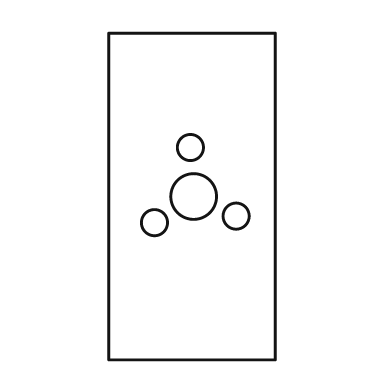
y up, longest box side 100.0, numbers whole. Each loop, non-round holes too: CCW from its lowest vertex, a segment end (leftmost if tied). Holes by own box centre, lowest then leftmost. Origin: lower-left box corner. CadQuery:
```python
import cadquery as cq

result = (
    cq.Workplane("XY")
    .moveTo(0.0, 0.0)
    .lineTo(51.0, 0.0)
    .lineTo(51.0, 100.0)
    .lineTo(0.0, 100.0)
    .close()
    .moveTo(14.0, 42.0)
    .circle(4.0)
    .moveTo(39.0, 44.0)
    .circle(4.0)
    .moveTo(26.0, 50.0)
    .circle(7.0)
    .moveTo(25.0, 65.0)
    .circle(4.0)
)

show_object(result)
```